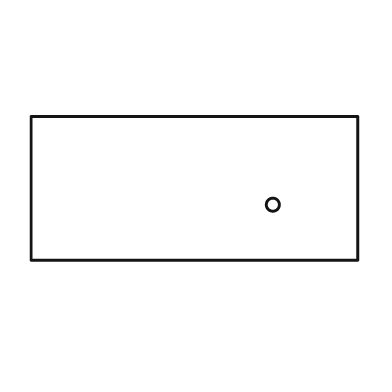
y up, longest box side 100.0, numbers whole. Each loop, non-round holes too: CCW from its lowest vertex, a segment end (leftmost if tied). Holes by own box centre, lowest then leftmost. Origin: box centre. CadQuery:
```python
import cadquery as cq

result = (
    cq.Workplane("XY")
    .moveTo(-50.0, -22.0)
    .lineTo(50.0, -22.0)
    .lineTo(50.0, 22.0)
    .lineTo(-50.0, 22.0)
    .close()
    .moveTo(24.0, -5.0)
    .circle(2.0)
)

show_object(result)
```